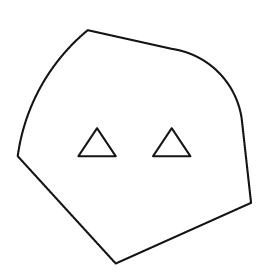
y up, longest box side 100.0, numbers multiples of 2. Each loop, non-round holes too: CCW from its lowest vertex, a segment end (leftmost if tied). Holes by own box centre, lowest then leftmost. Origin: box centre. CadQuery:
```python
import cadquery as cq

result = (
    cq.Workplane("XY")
    .moveTo(-8.0, -50.0)
    .lineTo(50.0, -24.0)
    .lineTo(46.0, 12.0)
    .threePointArc((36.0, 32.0), (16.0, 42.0))
    .lineTo(-20.0, 50.0)
    .threePointArc((-40.0, 26.0), (-50.0, -4.0))
    .close()
    .moveTo(-24.0, -4.0)
    .lineTo(-8.0, -4.0)
    .lineTo(-16.0, 8.0)
    .close()
    .moveTo(8.0, -4.0)
    .lineTo(24.0, -4.0)
    .lineTo(16.0, 8.0)
    .close()
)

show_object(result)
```